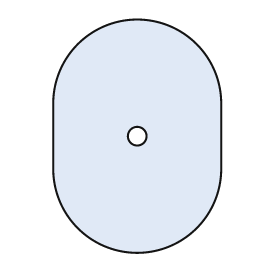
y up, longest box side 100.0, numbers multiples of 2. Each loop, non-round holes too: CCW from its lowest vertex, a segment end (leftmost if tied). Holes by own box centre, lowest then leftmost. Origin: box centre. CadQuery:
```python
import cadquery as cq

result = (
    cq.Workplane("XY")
    .moveTo(-36.0, -14.0)
    .threePointArc((0.0, -50.0), (36.0, -14.0))
    .lineTo(36.0, 14.0)
    .threePointArc((0.0, 50.0), (-36.0, 14.0))
    .close()
    .moveTo(0.0, 0.0)
    .circle(4.0)
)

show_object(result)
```